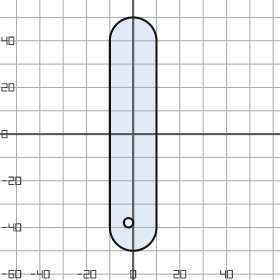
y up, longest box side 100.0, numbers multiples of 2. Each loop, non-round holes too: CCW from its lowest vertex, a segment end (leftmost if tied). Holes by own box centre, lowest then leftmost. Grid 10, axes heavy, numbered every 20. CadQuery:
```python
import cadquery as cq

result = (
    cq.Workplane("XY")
    .moveTo(-10.0, -40.0)
    .threePointArc((0.0, -50.0), (10.0, -40.0))
    .lineTo(10.0, 40.0)
    .threePointArc((0.0, 50.0), (-10.0, 40.0))
    .close()
    .moveTo(-2.0, -38.0)
    .circle(2.0)
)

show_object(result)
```